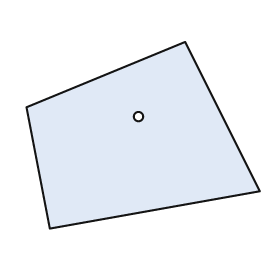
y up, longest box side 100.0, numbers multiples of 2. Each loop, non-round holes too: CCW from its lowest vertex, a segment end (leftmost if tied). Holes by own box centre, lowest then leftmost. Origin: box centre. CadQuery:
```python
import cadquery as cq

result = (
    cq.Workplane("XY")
    .moveTo(-40.0, -40.0)
    .lineTo(50.0, -24.0)
    .lineTo(18.0, 40.0)
    .lineTo(-50.0, 12.0)
    .close()
    .moveTo(-2.0, 8.0)
    .circle(2.0)
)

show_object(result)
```